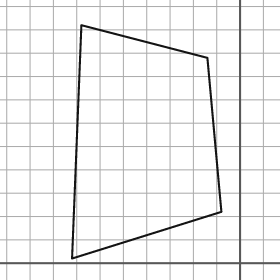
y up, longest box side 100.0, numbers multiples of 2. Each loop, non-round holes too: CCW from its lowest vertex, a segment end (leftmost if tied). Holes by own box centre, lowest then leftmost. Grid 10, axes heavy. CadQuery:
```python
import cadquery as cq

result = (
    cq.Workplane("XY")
    .moveTo(-72.0, 2.0)
    .lineTo(-8.0, 22.0)
    .lineTo(-14.0, 88.0)
    .lineTo(-68.0, 102.0)
    .close()
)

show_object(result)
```